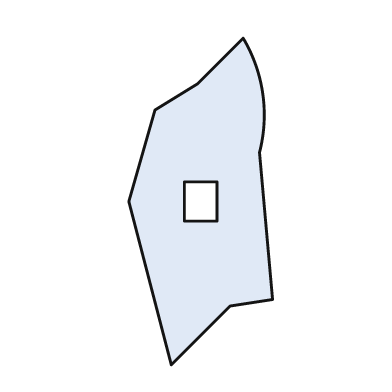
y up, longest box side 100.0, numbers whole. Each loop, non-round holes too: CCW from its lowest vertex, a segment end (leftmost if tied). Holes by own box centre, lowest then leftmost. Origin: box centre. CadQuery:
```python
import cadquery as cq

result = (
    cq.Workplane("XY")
    .moveTo(-9.0, -50.0)
    .lineTo(9.0, -32.0)
    .lineTo(22.0, -30.0)
    .lineTo(18.0, 15.0)
    .threePointArc((19.0, 33.0), (13.0, 50.0))
    .lineTo(-1.0, 36.0)
    .lineTo(-14.0, 28.0)
    .lineTo(-22.0, 0.0)
    .close()
    .moveTo(-5.0, -6.0)
    .lineTo(5.0, -6.0)
    .lineTo(5.0, 6.0)
    .lineTo(-5.0, 6.0)
    .close()
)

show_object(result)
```